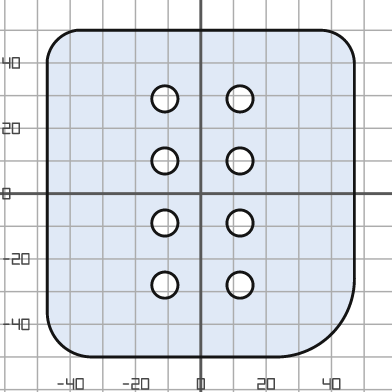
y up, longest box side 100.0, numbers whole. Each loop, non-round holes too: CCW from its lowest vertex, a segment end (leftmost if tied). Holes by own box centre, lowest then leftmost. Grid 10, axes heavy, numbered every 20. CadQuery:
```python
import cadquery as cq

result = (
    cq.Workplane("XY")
    .moveTo(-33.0, -50.0)
    .lineTo(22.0, -50.0)
    .threePointArc((40.0, -43.0), (47.0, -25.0))
    .lineTo(47.0, 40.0)
    .threePointArc((44.0, 47.0), (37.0, 50.0))
    .lineTo(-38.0, 50.0)
    .threePointArc((-44.0, 47.0), (-47.0, 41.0))
    .lineTo(-47.0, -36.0)
    .threePointArc((-43.0, -46.0), (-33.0, -50.0))
    .close()
    .moveTo(-11.0, -28.0)
    .circle(4.0)
    .moveTo(12.0, -28.0)
    .circle(4.0)
    .moveTo(-11.0, -9.0)
    .circle(4.0)
    .moveTo(12.0, -9.0)
    .circle(4.0)
    .moveTo(-11.0, 10.0)
    .circle(4.0)
    .moveTo(12.0, 10.0)
    .circle(4.0)
    .moveTo(-11.0, 29.0)
    .circle(4.0)
    .moveTo(12.0, 29.0)
    .circle(4.0)
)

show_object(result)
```